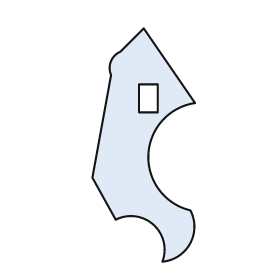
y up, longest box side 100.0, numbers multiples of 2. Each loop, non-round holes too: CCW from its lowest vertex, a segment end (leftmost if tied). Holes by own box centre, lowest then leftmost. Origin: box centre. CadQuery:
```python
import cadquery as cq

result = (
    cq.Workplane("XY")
    .moveTo(8.0, -50.0)
    .threePointArc((20.0, -42.0), (20.0, -28.0))
    .threePointArc((2.0, -4.0), (22.0, 18.0))
    .lineTo(0.0, 50.0)
    .lineTo(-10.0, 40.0)
    .threePointArc((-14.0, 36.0), (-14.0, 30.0))
    .lineTo(-22.0, -14.0)
    .lineTo(-12.0, -32.0)
    .threePointArc((4.0, -34.0), (8.0, -50.0))
    .close()
    .moveTo(-2.0, 14.0)
    .lineTo(6.0, 14.0)
    .lineTo(6.0, 26.0)
    .lineTo(-2.0, 26.0)
    .close()
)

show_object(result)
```